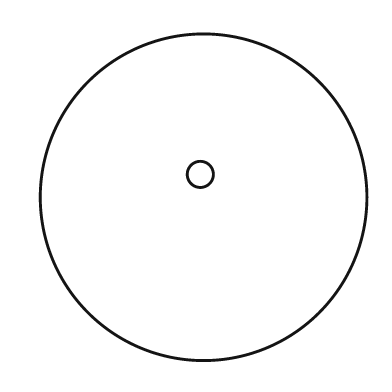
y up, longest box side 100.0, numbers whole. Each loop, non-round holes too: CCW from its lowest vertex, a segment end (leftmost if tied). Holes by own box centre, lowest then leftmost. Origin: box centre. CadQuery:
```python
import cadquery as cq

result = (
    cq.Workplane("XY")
    .moveTo(0.0, 0.0)
    .circle(50.0)
    .moveTo(-1.0, 7.0)
    .circle(4.0)
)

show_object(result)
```